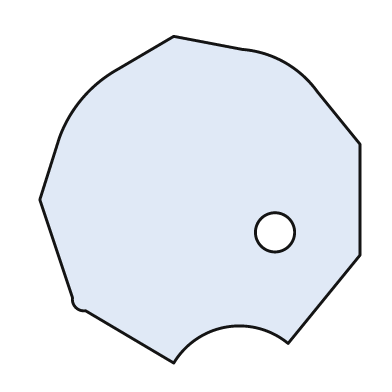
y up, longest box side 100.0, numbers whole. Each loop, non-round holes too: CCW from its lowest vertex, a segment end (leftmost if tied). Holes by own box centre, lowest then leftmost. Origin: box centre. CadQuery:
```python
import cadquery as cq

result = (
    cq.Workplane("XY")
    .moveTo(-8.0, -50.0)
    .threePointArc((8.0, -39.0), (27.0, -44.0))
    .lineTo(49.0, -17.0)
    .lineTo(49.0, 17.0)
    .lineTo(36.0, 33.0)
    .threePointArc((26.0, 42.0), (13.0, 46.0))
    .lineTo(-8.0, 50.0)
    .lineTo(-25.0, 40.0)
    .threePointArc((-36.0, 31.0), (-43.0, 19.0))
    .lineTo(-49.0, 0.0)
    .lineTo(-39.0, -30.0)
    .threePointArc((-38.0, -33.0), (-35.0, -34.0))
    .close()
    .moveTo(23.0, -10.0)
    .circle(6.0)
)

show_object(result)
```